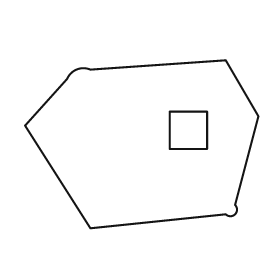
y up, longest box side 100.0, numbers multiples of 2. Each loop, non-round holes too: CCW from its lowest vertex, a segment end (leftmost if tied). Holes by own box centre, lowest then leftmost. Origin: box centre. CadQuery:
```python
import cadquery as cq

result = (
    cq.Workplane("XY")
    .moveTo(-22.0, -36.0)
    .lineTo(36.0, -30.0)
    .threePointArc((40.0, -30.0), (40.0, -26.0))
    .lineTo(50.0, 12.0)
    .lineTo(36.0, 36.0)
    .lineTo(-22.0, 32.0)
    .threePointArc((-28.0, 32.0), (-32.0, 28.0))
    .lineTo(-50.0, 8.0)
    .close()
    .moveTo(12.0, -2.0)
    .lineTo(28.0, -2.0)
    .lineTo(28.0, 14.0)
    .lineTo(12.0, 14.0)
    .close()
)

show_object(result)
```